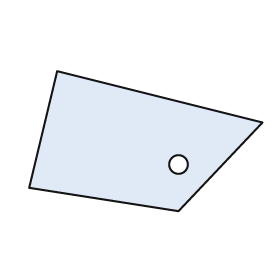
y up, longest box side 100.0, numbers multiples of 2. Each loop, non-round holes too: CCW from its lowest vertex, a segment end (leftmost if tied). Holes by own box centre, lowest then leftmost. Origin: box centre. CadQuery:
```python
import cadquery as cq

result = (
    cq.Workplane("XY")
    .moveTo(14.0, -30.0)
    .lineTo(50.0, 8.0)
    .lineTo(-38.0, 30.0)
    .lineTo(-50.0, -20.0)
    .close()
    .moveTo(14.0, -10.0)
    .circle(4.0)
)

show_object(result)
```